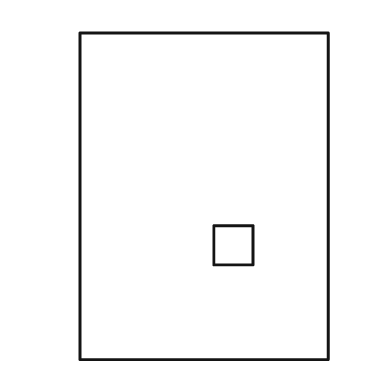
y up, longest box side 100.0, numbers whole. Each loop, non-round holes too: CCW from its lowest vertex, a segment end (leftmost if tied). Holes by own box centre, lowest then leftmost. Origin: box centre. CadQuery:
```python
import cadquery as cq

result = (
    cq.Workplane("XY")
    .moveTo(-38.0, -50.0)
    .lineTo(38.0, -50.0)
    .lineTo(38.0, 50.0)
    .lineTo(-38.0, 50.0)
    .close()
    .moveTo(3.0, -21.0)
    .lineTo(15.0, -21.0)
    .lineTo(15.0, -9.0)
    .lineTo(3.0, -9.0)
    .close()
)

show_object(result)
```